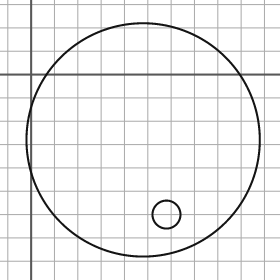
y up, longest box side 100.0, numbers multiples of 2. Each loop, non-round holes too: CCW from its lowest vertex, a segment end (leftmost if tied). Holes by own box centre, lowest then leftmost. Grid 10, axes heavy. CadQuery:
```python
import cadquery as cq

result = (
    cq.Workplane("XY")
    .moveTo(48.0, -28.0)
    .circle(50.0)
    .moveTo(58.0, -60.0)
    .circle(6.0)
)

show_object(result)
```